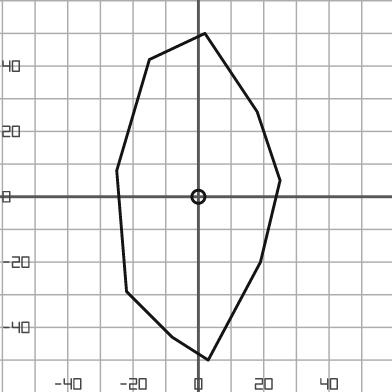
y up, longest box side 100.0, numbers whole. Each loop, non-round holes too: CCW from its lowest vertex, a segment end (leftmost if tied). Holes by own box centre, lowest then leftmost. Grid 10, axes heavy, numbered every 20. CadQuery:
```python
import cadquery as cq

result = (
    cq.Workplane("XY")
    .moveTo(3.0, -50.0)
    .lineTo(19.0, -20.0)
    .lineTo(25.0, 5.0)
    .lineTo(18.0, 26.0)
    .lineTo(2.0, 50.0)
    .lineTo(-15.0, 42.0)
    .lineTo(-25.0, 8.0)
    .lineTo(-22.0, -29.0)
    .lineTo(-8.0, -43.0)
    .close()
    .moveTo(0.0, 0.0)
    .circle(2.0)
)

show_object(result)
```